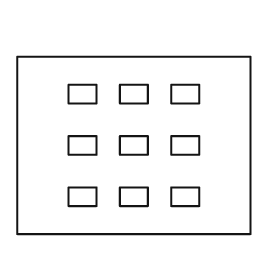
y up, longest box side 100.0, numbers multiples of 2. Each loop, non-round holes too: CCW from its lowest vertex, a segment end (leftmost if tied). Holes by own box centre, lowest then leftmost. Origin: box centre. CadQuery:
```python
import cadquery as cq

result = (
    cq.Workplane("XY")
    .moveTo(-50.0, -38.0)
    .lineTo(50.0, -38.0)
    .lineTo(50.0, 38.0)
    .lineTo(-50.0, 38.0)
    .close()
    .moveTo(-28.0, -26.0)
    .lineTo(-16.0, -26.0)
    .lineTo(-16.0, -18.0)
    .lineTo(-28.0, -18.0)
    .close()
    .moveTo(-6.0, -26.0)
    .lineTo(6.0, -26.0)
    .lineTo(6.0, -18.0)
    .lineTo(-6.0, -18.0)
    .close()
    .moveTo(16.0, -26.0)
    .lineTo(28.0, -26.0)
    .lineTo(28.0, -18.0)
    .lineTo(16.0, -18.0)
    .close()
    .moveTo(-28.0, -4.0)
    .lineTo(-16.0, -4.0)
    .lineTo(-16.0, 4.0)
    .lineTo(-28.0, 4.0)
    .close()
    .moveTo(-6.0, -4.0)
    .lineTo(6.0, -4.0)
    .lineTo(6.0, 4.0)
    .lineTo(-6.0, 4.0)
    .close()
    .moveTo(16.0, -4.0)
    .lineTo(28.0, -4.0)
    .lineTo(28.0, 4.0)
    .lineTo(16.0, 4.0)
    .close()
    .moveTo(-28.0, 18.0)
    .lineTo(-16.0, 18.0)
    .lineTo(-16.0, 26.0)
    .lineTo(-28.0, 26.0)
    .close()
    .moveTo(-6.0, 18.0)
    .lineTo(6.0, 18.0)
    .lineTo(6.0, 26.0)
    .lineTo(-6.0, 26.0)
    .close()
    .moveTo(16.0, 18.0)
    .lineTo(28.0, 18.0)
    .lineTo(28.0, 26.0)
    .lineTo(16.0, 26.0)
    .close()
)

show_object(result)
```